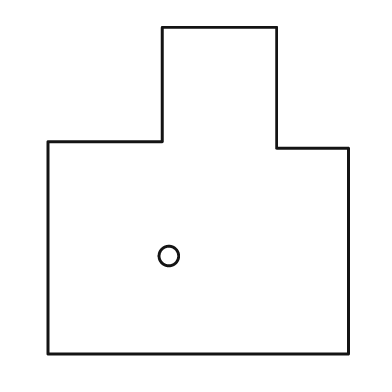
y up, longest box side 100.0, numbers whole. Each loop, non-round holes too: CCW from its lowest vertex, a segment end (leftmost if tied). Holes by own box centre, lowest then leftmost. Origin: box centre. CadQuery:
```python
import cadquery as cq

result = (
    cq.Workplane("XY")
    .moveTo(-46.0, -50.0)
    .lineTo(46.0, -50.0)
    .lineTo(46.0, 13.0)
    .lineTo(24.0, 13.0)
    .lineTo(24.0, 50.0)
    .lineTo(-11.0, 50.0)
    .lineTo(-11.0, 15.0)
    .lineTo(-46.0, 15.0)
    .close()
    .moveTo(-9.0, -20.0)
    .circle(3.0)
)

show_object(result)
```